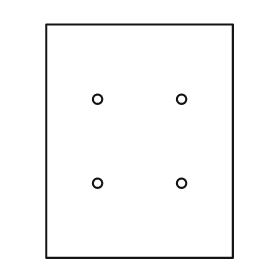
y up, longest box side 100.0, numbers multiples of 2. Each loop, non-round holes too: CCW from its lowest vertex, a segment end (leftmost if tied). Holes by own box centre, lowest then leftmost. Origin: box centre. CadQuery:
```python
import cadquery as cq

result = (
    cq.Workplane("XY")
    .moveTo(-40.0, -50.0)
    .lineTo(40.0, -50.0)
    .lineTo(40.0, 50.0)
    .lineTo(-40.0, 50.0)
    .close()
    .moveTo(-18.0, -18.0)
    .circle(2.0)
    .moveTo(18.0, -18.0)
    .circle(2.0)
    .moveTo(-18.0, 18.0)
    .circle(2.0)
    .moveTo(18.0, 18.0)
    .circle(2.0)
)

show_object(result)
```